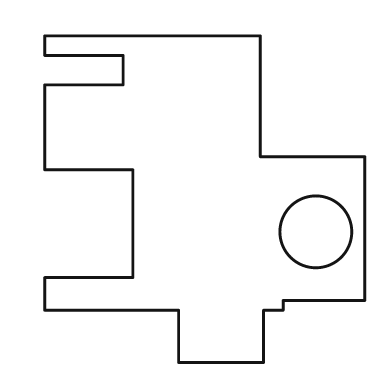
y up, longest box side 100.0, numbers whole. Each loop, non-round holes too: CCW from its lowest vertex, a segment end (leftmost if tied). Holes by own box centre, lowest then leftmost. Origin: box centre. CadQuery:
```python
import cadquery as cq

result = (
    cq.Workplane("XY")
    .moveTo(-8.0, -50.0)
    .lineTo(18.0, -50.0)
    .lineTo(18.0, -34.0)
    .lineTo(24.0, -34.0)
    .lineTo(24.0, -31.0)
    .lineTo(49.0, -31.0)
    .lineTo(49.0, 13.0)
    .lineTo(17.0, 13.0)
    .lineTo(17.0, 50.0)
    .lineTo(-49.0, 50.0)
    .lineTo(-49.0, 44.0)
    .lineTo(-25.0, 44.0)
    .lineTo(-25.0, 35.0)
    .lineTo(-49.0, 35.0)
    .lineTo(-49.0, 9.0)
    .lineTo(-22.0, 9.0)
    .lineTo(-22.0, -24.0)
    .lineTo(-49.0, -24.0)
    .lineTo(-49.0, -34.0)
    .lineTo(-8.0, -34.0)
    .close()
    .moveTo(34.0, -10.0)
    .circle(11.0)
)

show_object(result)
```